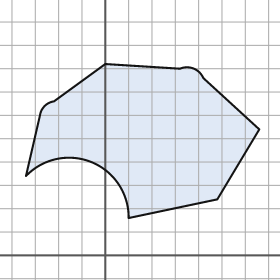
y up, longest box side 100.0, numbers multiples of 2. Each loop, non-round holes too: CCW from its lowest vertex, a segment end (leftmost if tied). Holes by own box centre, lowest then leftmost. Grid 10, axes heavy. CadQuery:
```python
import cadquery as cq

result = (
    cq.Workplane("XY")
    .moveTo(10.0, 16.0)
    .lineTo(48.0, 24.0)
    .lineTo(66.0, 54.0)
    .lineTo(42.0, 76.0)
    .threePointArc((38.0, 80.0), (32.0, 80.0))
    .lineTo(0.0, 82.0)
    .lineTo(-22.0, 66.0)
    .threePointArc((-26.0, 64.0), (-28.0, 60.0))
    .lineTo(-34.0, 34.0)
    .threePointArc((-6.0, 40.0), (10.0, 16.0))
    .close()
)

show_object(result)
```